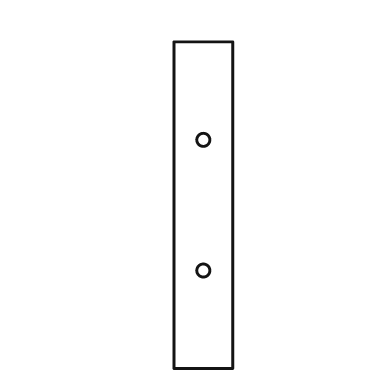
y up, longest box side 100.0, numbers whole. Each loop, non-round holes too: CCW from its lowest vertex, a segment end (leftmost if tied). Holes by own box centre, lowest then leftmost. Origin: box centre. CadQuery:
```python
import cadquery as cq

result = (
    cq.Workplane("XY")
    .moveTo(-9.0, -50.0)
    .lineTo(9.0, -50.0)
    .lineTo(9.0, 50.0)
    .lineTo(-9.0, 50.0)
    .close()
    .moveTo(0.0, -20.0)
    .circle(2.0)
    .moveTo(0.0, 20.0)
    .circle(2.0)
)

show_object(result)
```